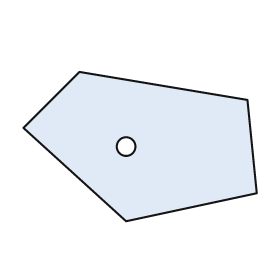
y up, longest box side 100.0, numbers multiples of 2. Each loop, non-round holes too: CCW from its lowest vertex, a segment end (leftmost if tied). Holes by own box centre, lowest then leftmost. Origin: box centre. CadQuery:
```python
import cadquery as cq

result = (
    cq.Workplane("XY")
    .moveTo(-6.0, -32.0)
    .lineTo(50.0, -20.0)
    .lineTo(46.0, 20.0)
    .lineTo(-26.0, 32.0)
    .lineTo(-50.0, 8.0)
    .close()
    .moveTo(-6.0, 0.0)
    .circle(4.0)
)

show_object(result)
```